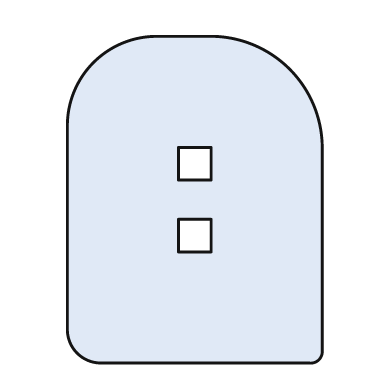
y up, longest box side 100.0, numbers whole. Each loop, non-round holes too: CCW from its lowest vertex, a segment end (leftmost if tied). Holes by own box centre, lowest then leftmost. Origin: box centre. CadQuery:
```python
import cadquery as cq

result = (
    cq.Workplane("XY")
    .moveTo(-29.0, -50.0)
    .lineTo(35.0, -50.0)
    .threePointArc((38.0, -49.0), (39.0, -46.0))
    .lineTo(39.0, 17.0)
    .threePointArc((29.0, 40.0), (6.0, 50.0))
    .lineTo(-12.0, 50.0)
    .threePointArc((-31.0, 42.0), (-39.0, 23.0))
    .lineTo(-39.0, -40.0)
    .threePointArc((-36.0, -47.0), (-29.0, -50.0))
    .close()
    .moveTo(-5.0, -16.0)
    .lineTo(5.0, -16.0)
    .lineTo(5.0, -6.0)
    .lineTo(-5.0, -6.0)
    .close()
    .moveTo(-5.0, 6.0)
    .lineTo(5.0, 6.0)
    .lineTo(5.0, 16.0)
    .lineTo(-5.0, 16.0)
    .close()
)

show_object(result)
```